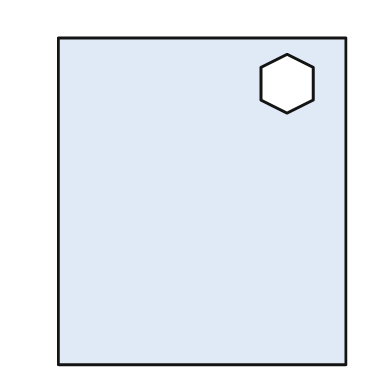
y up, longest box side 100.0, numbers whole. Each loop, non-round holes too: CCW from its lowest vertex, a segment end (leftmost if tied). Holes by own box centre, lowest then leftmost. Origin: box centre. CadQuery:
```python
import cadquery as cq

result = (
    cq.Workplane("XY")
    .moveTo(-44.0, -50.0)
    .lineTo(44.0, -50.0)
    .lineTo(44.0, 50.0)
    .lineTo(-44.0, 50.0)
    .close()
    .moveTo(26.0, 27.0)
    .lineTo(34.0, 31.0)
    .lineTo(34.0, 41.0)
    .lineTo(26.0, 45.0)
    .lineTo(18.0, 41.0)
    .lineTo(18.0, 31.0)
    .close()
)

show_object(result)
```